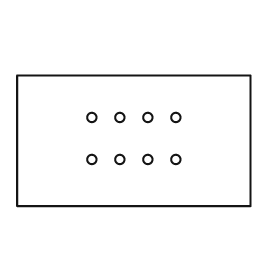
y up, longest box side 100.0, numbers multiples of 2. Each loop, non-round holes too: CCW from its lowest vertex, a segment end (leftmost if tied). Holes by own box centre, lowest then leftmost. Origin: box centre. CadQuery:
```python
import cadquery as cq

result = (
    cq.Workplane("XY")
    .moveTo(-50.0, -28.0)
    .lineTo(50.0, -28.0)
    .lineTo(50.0, 28.0)
    .lineTo(-50.0, 28.0)
    .close()
    .moveTo(-18.0, -8.0)
    .circle(2.0)
    .moveTo(-6.0, -8.0)
    .circle(2.0)
    .moveTo(6.0, -8.0)
    .circle(2.0)
    .moveTo(18.0, -8.0)
    .circle(2.0)
    .moveTo(-18.0, 10.0)
    .circle(2.0)
    .moveTo(-6.0, 10.0)
    .circle(2.0)
    .moveTo(6.0, 10.0)
    .circle(2.0)
    .moveTo(18.0, 10.0)
    .circle(2.0)
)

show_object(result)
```